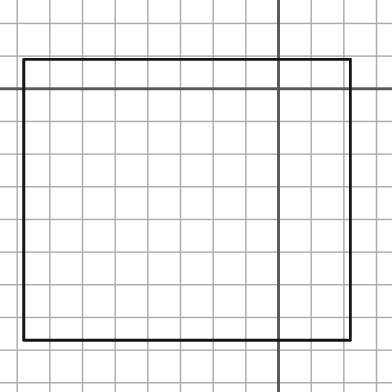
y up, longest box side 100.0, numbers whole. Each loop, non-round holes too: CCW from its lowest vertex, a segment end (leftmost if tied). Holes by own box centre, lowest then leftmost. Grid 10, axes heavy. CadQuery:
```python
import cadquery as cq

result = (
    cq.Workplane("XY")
    .moveTo(-78.0, -77.0)
    .lineTo(22.0, -77.0)
    .lineTo(22.0, 9.0)
    .lineTo(-78.0, 9.0)
    .close()
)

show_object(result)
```